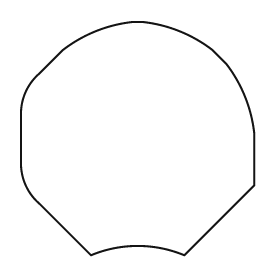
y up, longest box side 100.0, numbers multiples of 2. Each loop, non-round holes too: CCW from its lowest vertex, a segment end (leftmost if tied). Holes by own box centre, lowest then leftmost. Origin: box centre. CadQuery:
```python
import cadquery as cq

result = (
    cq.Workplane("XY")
    .moveTo(-20.0, -50.0)
    .threePointArc((0.0, -46.0), (20.0, -50.0))
    .lineTo(50.0, -20.0)
    .lineTo(50.0, 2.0)
    .threePointArc((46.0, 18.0), (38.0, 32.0))
    .lineTo(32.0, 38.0)
    .threePointArc((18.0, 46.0), (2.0, 50.0))
    .lineTo(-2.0, 50.0)
    .threePointArc((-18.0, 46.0), (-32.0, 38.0))
    .lineTo(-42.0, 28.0)
    .threePointArc((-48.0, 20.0), (-50.0, 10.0))
    .lineTo(-50.0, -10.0)
    .threePointArc((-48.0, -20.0), (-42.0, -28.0))
    .close()
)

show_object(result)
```